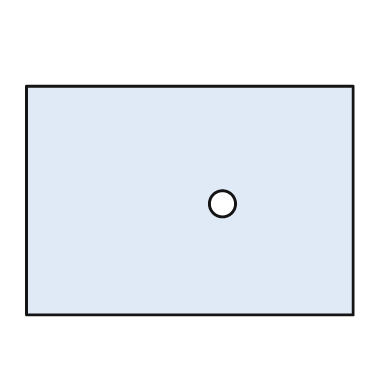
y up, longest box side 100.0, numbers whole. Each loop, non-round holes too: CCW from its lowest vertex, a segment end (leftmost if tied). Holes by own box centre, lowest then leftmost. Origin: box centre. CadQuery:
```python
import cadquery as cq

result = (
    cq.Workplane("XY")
    .moveTo(-50.0, -35.0)
    .lineTo(50.0, -35.0)
    .lineTo(50.0, 35.0)
    .lineTo(-50.0, 35.0)
    .close()
    .moveTo(10.0, -1.0)
    .circle(4.0)
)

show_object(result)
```